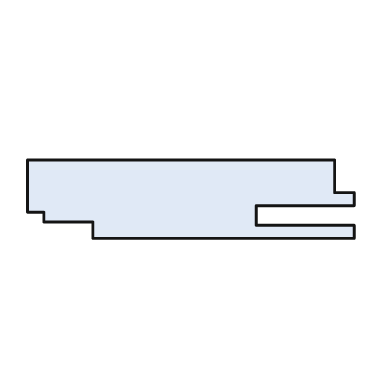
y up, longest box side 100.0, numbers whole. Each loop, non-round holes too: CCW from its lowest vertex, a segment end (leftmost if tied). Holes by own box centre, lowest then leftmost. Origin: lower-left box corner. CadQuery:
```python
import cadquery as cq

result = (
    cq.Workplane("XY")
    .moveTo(20.0, 0.0)
    .lineTo(100.0, 0.0)
    .lineTo(100.0, 4.0)
    .lineTo(70.0, 4.0)
    .lineTo(70.0, 10.0)
    .lineTo(100.0, 10.0)
    .lineTo(100.0, 14.0)
    .lineTo(94.0, 14.0)
    .lineTo(94.0, 24.0)
    .lineTo(0.0, 24.0)
    .lineTo(0.0, 8.0)
    .lineTo(5.0, 8.0)
    .lineTo(5.0, 5.0)
    .lineTo(20.0, 5.0)
    .close()
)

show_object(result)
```